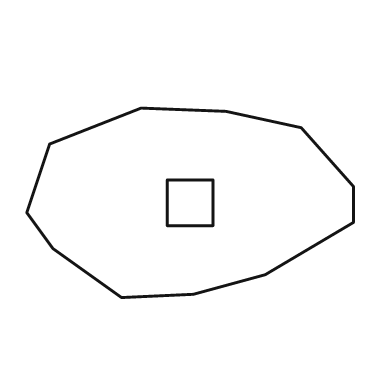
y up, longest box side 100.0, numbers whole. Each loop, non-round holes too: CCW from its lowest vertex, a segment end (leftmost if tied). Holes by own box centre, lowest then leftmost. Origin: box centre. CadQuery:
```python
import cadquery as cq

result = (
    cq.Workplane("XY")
    .moveTo(-21.0, -29.0)
    .lineTo(1.0, -28.0)
    .lineTo(23.0, -22.0)
    .lineTo(50.0, -6.0)
    .lineTo(50.0, 5.0)
    .lineTo(34.0, 23.0)
    .lineTo(11.0, 28.0)
    .lineTo(-15.0, 29.0)
    .lineTo(-43.0, 18.0)
    .lineTo(-50.0, -3.0)
    .lineTo(-42.0, -14.0)
    .close()
    .moveTo(-7.0, -7.0)
    .lineTo(7.0, -7.0)
    .lineTo(7.0, 7.0)
    .lineTo(-7.0, 7.0)
    .close()
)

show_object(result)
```